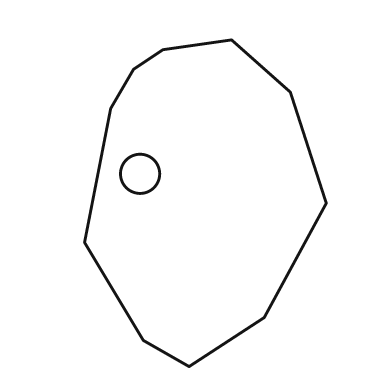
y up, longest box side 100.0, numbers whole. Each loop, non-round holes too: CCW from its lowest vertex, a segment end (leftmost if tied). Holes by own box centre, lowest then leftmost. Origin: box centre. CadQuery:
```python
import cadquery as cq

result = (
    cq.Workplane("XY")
    .moveTo(-5.0, -50.0)
    .lineTo(18.0, -35.0)
    .lineTo(37.0, 0.0)
    .lineTo(26.0, 34.0)
    .lineTo(8.0, 50.0)
    .lineTo(-13.0, 47.0)
    .lineTo(-22.0, 41.0)
    .lineTo(-29.0, 29.0)
    .lineTo(-37.0, -12.0)
    .lineTo(-19.0, -42.0)
    .close()
    .moveTo(-20.0, 9.0)
    .circle(6.0)
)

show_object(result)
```